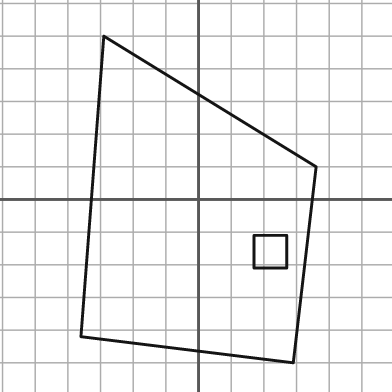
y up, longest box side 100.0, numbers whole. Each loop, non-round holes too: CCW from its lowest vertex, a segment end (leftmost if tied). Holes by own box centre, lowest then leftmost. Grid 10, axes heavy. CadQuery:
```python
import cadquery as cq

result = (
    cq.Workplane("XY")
    .moveTo(29.0, -50.0)
    .lineTo(36.0, 10.0)
    .lineTo(-29.0, 50.0)
    .lineTo(-36.0, -42.0)
    .close()
    .moveTo(17.0, -21.0)
    .lineTo(27.0, -21.0)
    .lineTo(27.0, -11.0)
    .lineTo(17.0, -11.0)
    .close()
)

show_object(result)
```